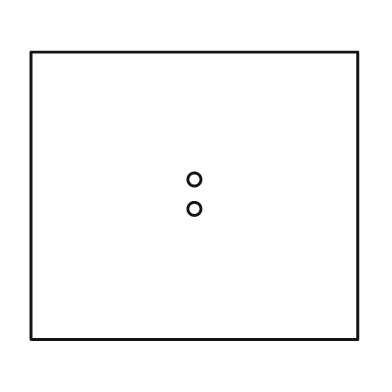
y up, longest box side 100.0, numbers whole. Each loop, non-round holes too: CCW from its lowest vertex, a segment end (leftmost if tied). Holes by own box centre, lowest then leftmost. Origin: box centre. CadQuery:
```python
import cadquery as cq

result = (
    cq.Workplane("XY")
    .moveTo(-50.0, -44.0)
    .lineTo(50.0, -44.0)
    .lineTo(50.0, 44.0)
    .lineTo(-50.0, 44.0)
    .close()
    .moveTo(0.0, -4.0)
    .circle(2.0)
    .moveTo(0.0, 5.0)
    .circle(2.0)
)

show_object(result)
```